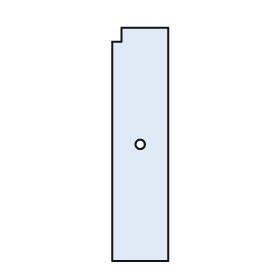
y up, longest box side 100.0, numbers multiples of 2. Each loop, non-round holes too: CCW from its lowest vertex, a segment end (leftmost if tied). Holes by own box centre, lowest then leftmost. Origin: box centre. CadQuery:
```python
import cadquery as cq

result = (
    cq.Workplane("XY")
    .moveTo(-12.0, -50.0)
    .lineTo(12.0, -50.0)
    .lineTo(12.0, 50.0)
    .lineTo(-8.0, 50.0)
    .lineTo(-8.0, 44.0)
    .lineTo(-12.0, 44.0)
    .close()
    .moveTo(0.0, 0.0)
    .circle(2.0)
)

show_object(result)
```